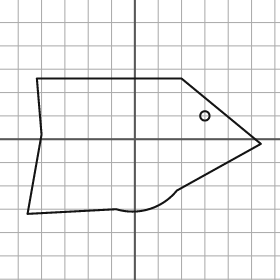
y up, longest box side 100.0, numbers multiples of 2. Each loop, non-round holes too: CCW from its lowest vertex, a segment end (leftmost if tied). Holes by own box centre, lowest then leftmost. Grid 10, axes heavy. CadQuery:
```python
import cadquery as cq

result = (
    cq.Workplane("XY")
    .moveTo(-46.0, -32.0)
    .lineTo(-8.0, -30.0)
    .threePointArc((6.0, -30.0), (18.0, -22.0))
    .lineTo(54.0, -2.0)
    .lineTo(20.0, 26.0)
    .lineTo(-42.0, 26.0)
    .lineTo(-40.0, 2.0)
    .close()
    .moveTo(30.0, 10.0)
    .circle(2.0)
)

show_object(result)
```